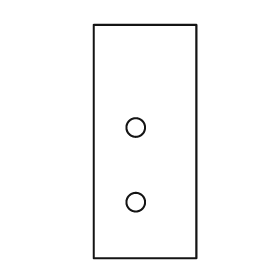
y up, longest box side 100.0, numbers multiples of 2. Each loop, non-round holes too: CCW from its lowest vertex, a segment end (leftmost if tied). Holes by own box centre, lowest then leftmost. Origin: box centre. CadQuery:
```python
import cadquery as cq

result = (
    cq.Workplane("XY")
    .moveTo(-22.0, -50.0)
    .lineTo(22.0, -50.0)
    .lineTo(22.0, 50.0)
    .lineTo(-22.0, 50.0)
    .close()
    .moveTo(-4.0, -26.0)
    .circle(4.0)
    .moveTo(-4.0, 6.0)
    .circle(4.0)
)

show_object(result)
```